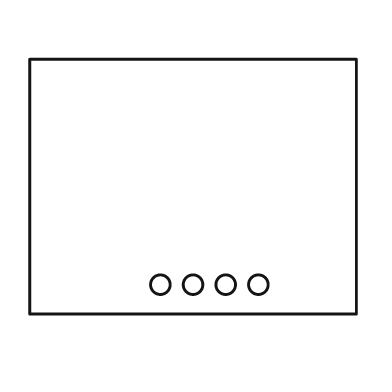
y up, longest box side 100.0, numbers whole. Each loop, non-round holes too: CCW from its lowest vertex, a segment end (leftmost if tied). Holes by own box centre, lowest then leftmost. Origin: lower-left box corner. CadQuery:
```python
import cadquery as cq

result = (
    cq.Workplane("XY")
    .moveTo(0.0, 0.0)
    .lineTo(100.0, 0.0)
    .lineTo(100.0, 78.0)
    .lineTo(0.0, 78.0)
    .close()
    .moveTo(40.0, 9.0)
    .circle(3.0)
    .moveTo(50.0, 9.0)
    .circle(3.0)
    .moveTo(60.0, 9.0)
    .circle(3.0)
    .moveTo(70.0, 9.0)
    .circle(3.0)
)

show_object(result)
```